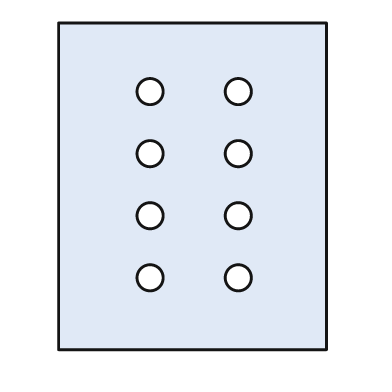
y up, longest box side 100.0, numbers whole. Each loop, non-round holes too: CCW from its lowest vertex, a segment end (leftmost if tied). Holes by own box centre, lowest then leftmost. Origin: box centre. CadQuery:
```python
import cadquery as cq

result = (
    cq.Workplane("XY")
    .moveTo(-41.0, -50.0)
    .lineTo(41.0, -50.0)
    .lineTo(41.0, 50.0)
    .lineTo(-41.0, 50.0)
    .close()
    .moveTo(-13.0, -28.0)
    .circle(4.0)
    .moveTo(14.0, -28.0)
    .circle(4.0)
    .moveTo(-13.0, -9.0)
    .circle(4.0)
    .moveTo(14.0, -9.0)
    .circle(4.0)
    .moveTo(-13.0, 10.0)
    .circle(4.0)
    .moveTo(14.0, 10.0)
    .circle(4.0)
    .moveTo(-13.0, 29.0)
    .circle(4.0)
    .moveTo(14.0, 29.0)
    .circle(4.0)
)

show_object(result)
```